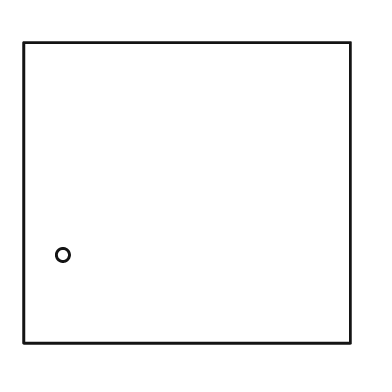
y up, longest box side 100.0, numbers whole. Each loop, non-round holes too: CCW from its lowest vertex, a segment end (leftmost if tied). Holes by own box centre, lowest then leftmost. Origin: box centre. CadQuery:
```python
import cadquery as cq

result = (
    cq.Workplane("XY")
    .moveTo(-50.0, -46.0)
    .lineTo(50.0, -46.0)
    .lineTo(50.0, 46.0)
    .lineTo(-50.0, 46.0)
    .close()
    .moveTo(-38.0, -19.0)
    .circle(2.0)
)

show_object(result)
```